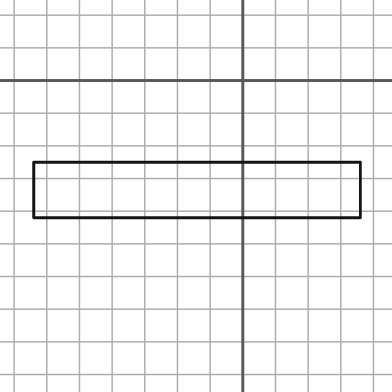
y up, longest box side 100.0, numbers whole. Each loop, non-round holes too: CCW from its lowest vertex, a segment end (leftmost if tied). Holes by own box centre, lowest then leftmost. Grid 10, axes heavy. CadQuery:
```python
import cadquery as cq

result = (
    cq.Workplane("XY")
    .moveTo(-64.0, -42.0)
    .lineTo(36.0, -42.0)
    .lineTo(36.0, -25.0)
    .lineTo(-64.0, -25.0)
    .close()
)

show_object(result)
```